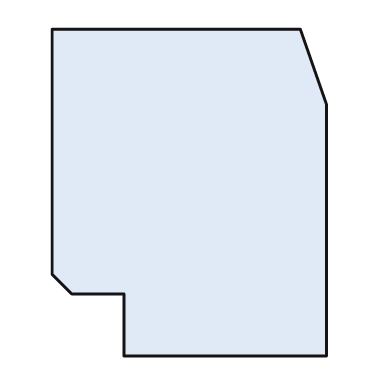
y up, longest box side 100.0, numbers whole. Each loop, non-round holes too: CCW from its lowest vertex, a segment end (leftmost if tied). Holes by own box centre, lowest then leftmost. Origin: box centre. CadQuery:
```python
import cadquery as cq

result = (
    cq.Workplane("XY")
    .moveTo(-20.0, -50.0)
    .lineTo(42.0, -50.0)
    .lineTo(42.0, 27.0)
    .lineTo(34.0, 50.0)
    .lineTo(-42.0, 50.0)
    .lineTo(-42.0, -25.0)
    .lineTo(-36.0, -31.0)
    .lineTo(-20.0, -31.0)
    .close()
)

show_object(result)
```